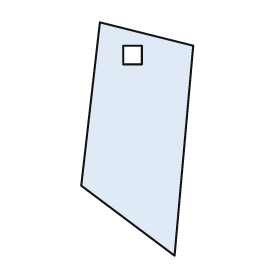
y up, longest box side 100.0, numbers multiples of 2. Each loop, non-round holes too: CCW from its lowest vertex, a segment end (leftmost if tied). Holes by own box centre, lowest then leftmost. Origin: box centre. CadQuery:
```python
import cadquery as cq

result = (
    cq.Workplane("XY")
    .moveTo(16.0, -50.0)
    .lineTo(24.0, 40.0)
    .lineTo(-16.0, 50.0)
    .lineTo(-24.0, -20.0)
    .close()
    .moveTo(-6.0, 32.0)
    .lineTo(2.0, 32.0)
    .lineTo(2.0, 40.0)
    .lineTo(-6.0, 40.0)
    .close()
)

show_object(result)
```